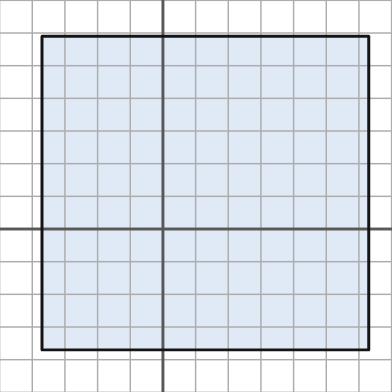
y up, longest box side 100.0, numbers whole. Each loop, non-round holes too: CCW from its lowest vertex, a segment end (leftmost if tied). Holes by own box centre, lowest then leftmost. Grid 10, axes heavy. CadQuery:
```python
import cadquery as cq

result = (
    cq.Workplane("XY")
    .moveTo(-37.0, -37.0)
    .lineTo(63.0, -37.0)
    .lineTo(63.0, 59.0)
    .lineTo(-37.0, 59.0)
    .close()
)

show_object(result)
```